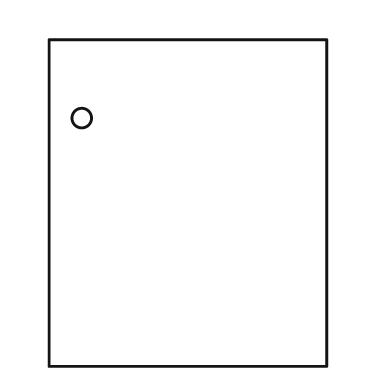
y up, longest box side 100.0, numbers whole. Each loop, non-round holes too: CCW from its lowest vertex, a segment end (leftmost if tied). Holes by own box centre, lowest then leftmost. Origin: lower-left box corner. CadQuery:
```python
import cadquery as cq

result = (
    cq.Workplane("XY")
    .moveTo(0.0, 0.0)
    .lineTo(85.0, 0.0)
    .lineTo(85.0, 100.0)
    .lineTo(0.0, 100.0)
    .close()
    .moveTo(10.0, 76.0)
    .circle(3.0)
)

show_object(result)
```